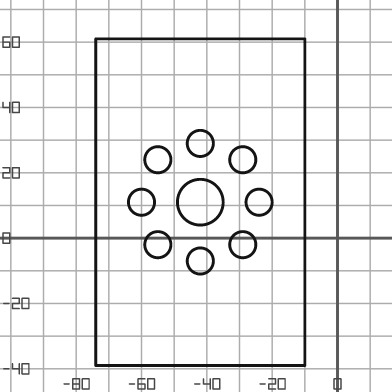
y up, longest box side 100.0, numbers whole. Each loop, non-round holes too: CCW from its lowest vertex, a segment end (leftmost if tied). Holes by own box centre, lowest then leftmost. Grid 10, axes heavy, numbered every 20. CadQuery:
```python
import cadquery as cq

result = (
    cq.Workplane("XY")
    .moveTo(-74.0, -39.0)
    .lineTo(-10.0, -39.0)
    .lineTo(-10.0, 61.0)
    .lineTo(-74.0, 61.0)
    .close()
    .moveTo(-42.0, -7.0)
    .circle(4.0)
    .moveTo(-55.0, -2.0)
    .circle(4.0)
    .moveTo(-29.0, -2.0)
    .circle(4.0)
    .moveTo(-60.0, 11.0)
    .circle(4.0)
    .moveTo(-42.0, 11.0)
    .circle(7.0)
    .moveTo(-24.0, 11.0)
    .circle(4.0)
    .moveTo(-55.0, 24.0)
    .circle(4.0)
    .moveTo(-29.0, 24.0)
    .circle(4.0)
    .moveTo(-42.0, 29.0)
    .circle(4.0)
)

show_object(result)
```